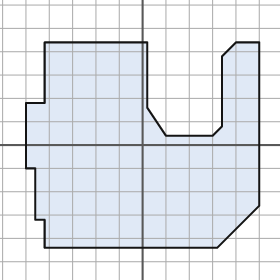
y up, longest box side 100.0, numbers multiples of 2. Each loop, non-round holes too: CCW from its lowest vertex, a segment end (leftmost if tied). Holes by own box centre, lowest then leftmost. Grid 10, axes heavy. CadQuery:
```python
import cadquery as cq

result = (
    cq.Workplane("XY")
    .moveTo(-42.0, -44.0)
    .lineTo(32.0, -44.0)
    .lineTo(50.0, -26.0)
    .lineTo(50.0, 44.0)
    .lineTo(40.0, 44.0)
    .lineTo(34.0, 38.0)
    .lineTo(34.0, 8.0)
    .lineTo(30.0, 4.0)
    .lineTo(10.0, 4.0)
    .lineTo(2.0, 16.0)
    .lineTo(2.0, 44.0)
    .lineTo(-42.0, 44.0)
    .lineTo(-42.0, 18.0)
    .lineTo(-50.0, 18.0)
    .lineTo(-50.0, -10.0)
    .lineTo(-46.0, -10.0)
    .lineTo(-46.0, -32.0)
    .lineTo(-42.0, -32.0)
    .close()
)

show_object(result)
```